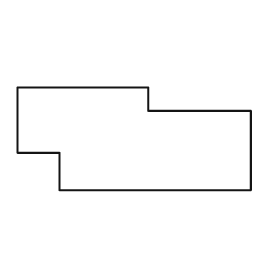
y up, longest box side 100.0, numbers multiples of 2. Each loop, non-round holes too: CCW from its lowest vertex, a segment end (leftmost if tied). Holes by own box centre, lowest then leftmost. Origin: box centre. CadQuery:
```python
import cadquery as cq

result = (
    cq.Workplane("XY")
    .moveTo(-32.0, -22.0)
    .lineTo(50.0, -22.0)
    .lineTo(50.0, 12.0)
    .lineTo(6.0, 12.0)
    .lineTo(6.0, 22.0)
    .lineTo(-50.0, 22.0)
    .lineTo(-50.0, -6.0)
    .lineTo(-32.0, -6.0)
    .close()
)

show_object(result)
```